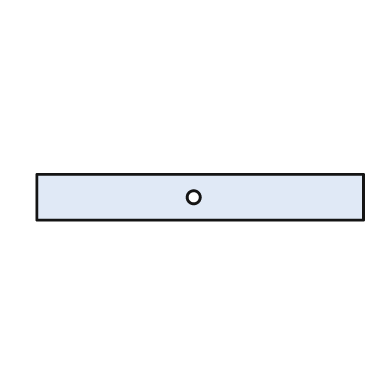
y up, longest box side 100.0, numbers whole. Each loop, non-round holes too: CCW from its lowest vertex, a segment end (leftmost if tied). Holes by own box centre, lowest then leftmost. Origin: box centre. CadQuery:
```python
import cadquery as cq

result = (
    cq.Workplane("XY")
    .moveTo(-50.0, -7.0)
    .lineTo(50.0, -7.0)
    .lineTo(50.0, 7.0)
    .lineTo(-50.0, 7.0)
    .close()
    .moveTo(-2.0, 0.0)
    .circle(2.0)
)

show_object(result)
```